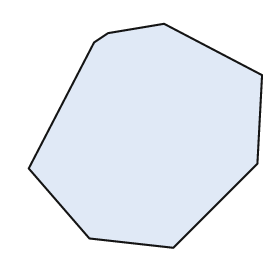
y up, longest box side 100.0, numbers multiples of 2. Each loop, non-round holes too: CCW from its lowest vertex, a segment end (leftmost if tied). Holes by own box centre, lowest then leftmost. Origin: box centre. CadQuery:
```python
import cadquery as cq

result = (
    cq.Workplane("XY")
    .moveTo(12.0, -48.0)
    .lineTo(48.0, -12.0)
    .lineTo(50.0, 26.0)
    .lineTo(8.0, 48.0)
    .lineTo(-16.0, 44.0)
    .lineTo(-22.0, 40.0)
    .lineTo(-50.0, -14.0)
    .lineTo(-24.0, -44.0)
    .close()
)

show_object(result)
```